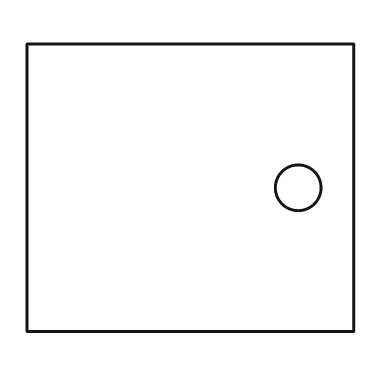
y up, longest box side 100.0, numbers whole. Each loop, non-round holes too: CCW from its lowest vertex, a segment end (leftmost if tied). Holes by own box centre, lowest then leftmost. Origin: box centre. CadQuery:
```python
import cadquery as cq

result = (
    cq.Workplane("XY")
    .moveTo(-50.0, -44.0)
    .lineTo(50.0, -44.0)
    .lineTo(50.0, 44.0)
    .lineTo(-50.0, 44.0)
    .close()
    .moveTo(33.0, 0.0)
    .circle(7.0)
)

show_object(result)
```